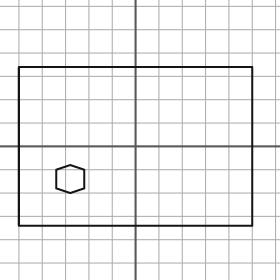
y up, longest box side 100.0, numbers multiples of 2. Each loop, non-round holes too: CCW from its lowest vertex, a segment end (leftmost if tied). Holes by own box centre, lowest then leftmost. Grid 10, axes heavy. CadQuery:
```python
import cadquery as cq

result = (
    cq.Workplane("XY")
    .moveTo(-50.0, -34.0)
    .lineTo(50.0, -34.0)
    .lineTo(50.0, 34.0)
    .lineTo(-50.0, 34.0)
    .close()
    .moveTo(-28.0, -20.0)
    .lineTo(-22.0, -18.0)
    .lineTo(-22.0, -10.0)
    .lineTo(-28.0, -8.0)
    .lineTo(-34.0, -10.0)
    .lineTo(-34.0, -18.0)
    .close()
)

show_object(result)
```